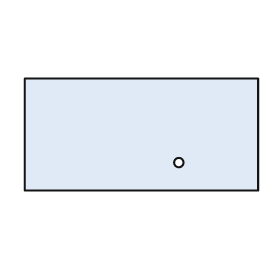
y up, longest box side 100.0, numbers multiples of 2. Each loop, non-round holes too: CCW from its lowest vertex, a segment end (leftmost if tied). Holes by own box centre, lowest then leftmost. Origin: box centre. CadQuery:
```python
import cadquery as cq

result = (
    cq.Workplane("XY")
    .moveTo(-50.0, -24.0)
    .lineTo(50.0, -24.0)
    .lineTo(50.0, 24.0)
    .lineTo(-50.0, 24.0)
    .close()
    .moveTo(16.0, -12.0)
    .circle(2.0)
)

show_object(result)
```